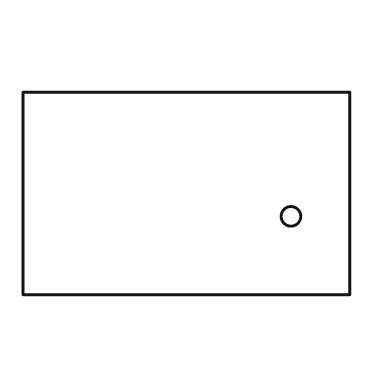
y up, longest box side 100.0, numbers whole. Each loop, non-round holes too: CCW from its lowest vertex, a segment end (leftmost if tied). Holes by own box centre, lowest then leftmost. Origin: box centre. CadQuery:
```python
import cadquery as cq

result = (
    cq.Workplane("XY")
    .moveTo(-50.0, -31.0)
    .lineTo(50.0, -31.0)
    .lineTo(50.0, 31.0)
    .lineTo(-50.0, 31.0)
    .close()
    .moveTo(32.0, -7.0)
    .circle(3.0)
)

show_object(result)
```